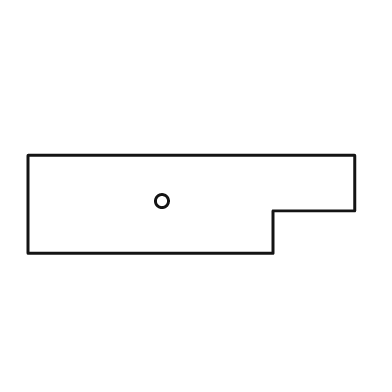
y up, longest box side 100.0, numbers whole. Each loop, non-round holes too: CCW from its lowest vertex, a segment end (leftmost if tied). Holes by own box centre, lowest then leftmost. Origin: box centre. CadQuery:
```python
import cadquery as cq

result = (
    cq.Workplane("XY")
    .moveTo(-50.0, -15.0)
    .lineTo(25.0, -15.0)
    .lineTo(25.0, -2.0)
    .lineTo(50.0, -2.0)
    .lineTo(50.0, 15.0)
    .lineTo(-50.0, 15.0)
    .close()
    .moveTo(-9.0, 1.0)
    .circle(2.0)
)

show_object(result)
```